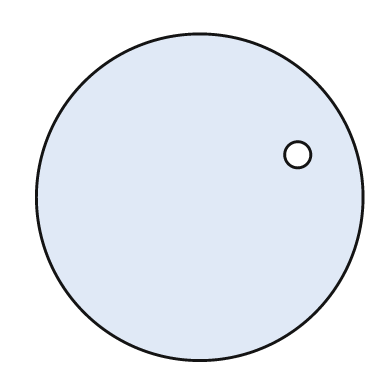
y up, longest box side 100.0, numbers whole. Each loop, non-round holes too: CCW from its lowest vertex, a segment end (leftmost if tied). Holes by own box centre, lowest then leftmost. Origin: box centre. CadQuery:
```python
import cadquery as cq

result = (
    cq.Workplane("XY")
    .moveTo(0.0, 0.0)
    .circle(50.0)
    .moveTo(30.0, 13.0)
    .circle(4.0)
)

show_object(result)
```